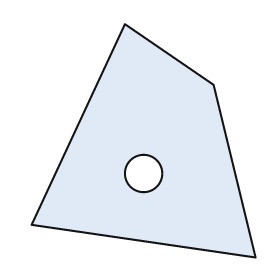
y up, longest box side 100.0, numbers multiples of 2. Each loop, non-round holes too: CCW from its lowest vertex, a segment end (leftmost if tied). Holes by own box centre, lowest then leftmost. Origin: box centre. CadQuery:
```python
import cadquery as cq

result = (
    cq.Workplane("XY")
    .moveTo(48.0, -50.0)
    .lineTo(30.0, 24.0)
    .lineTo(-8.0, 50.0)
    .lineTo(-48.0, -36.0)
    .close()
    .moveTo(0.0, -14.0)
    .circle(8.0)
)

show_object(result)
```